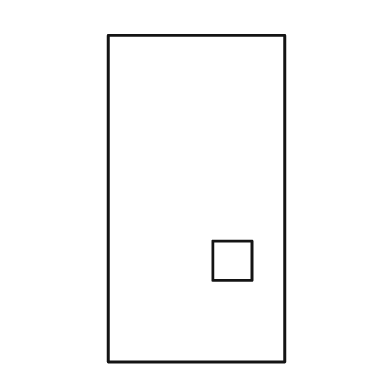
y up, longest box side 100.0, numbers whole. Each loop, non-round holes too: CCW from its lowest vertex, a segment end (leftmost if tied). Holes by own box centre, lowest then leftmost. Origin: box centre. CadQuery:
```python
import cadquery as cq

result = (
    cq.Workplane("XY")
    .moveTo(-27.0, -50.0)
    .lineTo(27.0, -50.0)
    .lineTo(27.0, 50.0)
    .lineTo(-27.0, 50.0)
    .close()
    .moveTo(5.0, -25.0)
    .lineTo(17.0, -25.0)
    .lineTo(17.0, -13.0)
    .lineTo(5.0, -13.0)
    .close()
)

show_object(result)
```